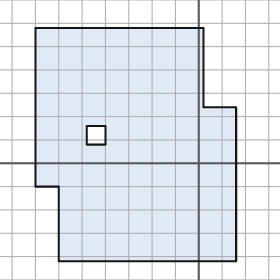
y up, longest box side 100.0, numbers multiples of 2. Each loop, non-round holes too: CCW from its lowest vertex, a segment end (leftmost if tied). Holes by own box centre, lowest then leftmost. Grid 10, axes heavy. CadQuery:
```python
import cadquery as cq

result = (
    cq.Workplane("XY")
    .moveTo(-60.0, -42.0)
    .lineTo(16.0, -42.0)
    .lineTo(16.0, 24.0)
    .lineTo(2.0, 24.0)
    .lineTo(2.0, 58.0)
    .lineTo(-70.0, 58.0)
    .lineTo(-70.0, -10.0)
    .lineTo(-60.0, -10.0)
    .close()
    .moveTo(-48.0, 8.0)
    .lineTo(-40.0, 8.0)
    .lineTo(-40.0, 16.0)
    .lineTo(-48.0, 16.0)
    .close()
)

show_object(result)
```